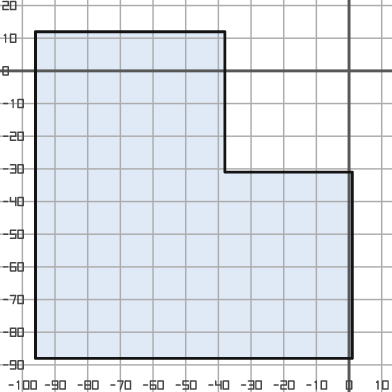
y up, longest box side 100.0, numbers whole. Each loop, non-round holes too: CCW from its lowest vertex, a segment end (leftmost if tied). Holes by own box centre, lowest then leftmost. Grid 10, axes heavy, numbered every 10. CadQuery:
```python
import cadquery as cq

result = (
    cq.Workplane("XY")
    .moveTo(-96.0, -88.0)
    .lineTo(1.0, -88.0)
    .lineTo(1.0, -31.0)
    .lineTo(-38.0, -31.0)
    .lineTo(-38.0, 12.0)
    .lineTo(-96.0, 12.0)
    .close()
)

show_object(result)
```